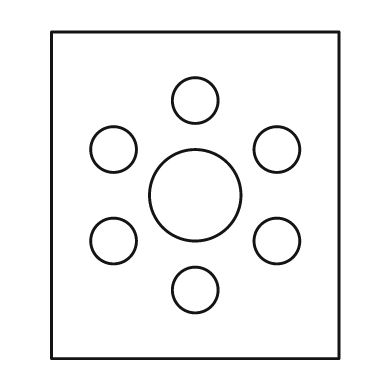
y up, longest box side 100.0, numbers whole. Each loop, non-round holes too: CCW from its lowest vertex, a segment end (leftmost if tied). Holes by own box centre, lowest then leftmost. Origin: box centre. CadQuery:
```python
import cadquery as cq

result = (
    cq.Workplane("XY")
    .moveTo(-44.0, -50.0)
    .lineTo(44.0, -50.0)
    .lineTo(44.0, 50.0)
    .lineTo(-44.0, 50.0)
    .close()
    .moveTo(0.0, -29.0)
    .circle(7.0)
    .moveTo(-25.0, -14.0)
    .circle(7.0)
    .moveTo(25.0, -14.0)
    .circle(7.0)
    .moveTo(0.0, 0.0)
    .circle(14.0)
    .moveTo(-25.0, 14.0)
    .circle(7.0)
    .moveTo(25.0, 14.0)
    .circle(7.0)
    .moveTo(0.0, 29.0)
    .circle(7.0)
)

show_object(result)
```